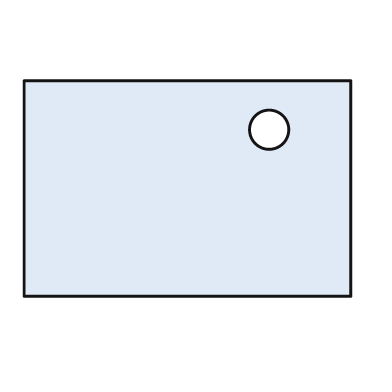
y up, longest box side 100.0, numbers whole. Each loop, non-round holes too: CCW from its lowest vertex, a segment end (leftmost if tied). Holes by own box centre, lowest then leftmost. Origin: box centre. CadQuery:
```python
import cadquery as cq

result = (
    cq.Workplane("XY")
    .moveTo(-50.0, -33.0)
    .lineTo(50.0, -33.0)
    .lineTo(50.0, 33.0)
    .lineTo(-50.0, 33.0)
    .close()
    .moveTo(25.0, 18.0)
    .circle(6.0)
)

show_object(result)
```